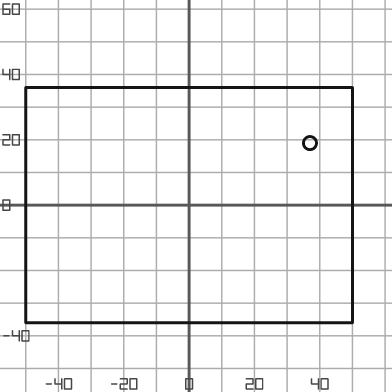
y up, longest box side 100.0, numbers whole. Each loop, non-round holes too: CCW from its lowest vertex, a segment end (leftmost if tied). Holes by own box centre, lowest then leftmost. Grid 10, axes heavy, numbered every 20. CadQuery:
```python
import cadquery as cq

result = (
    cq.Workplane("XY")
    .moveTo(-50.0, -36.0)
    .lineTo(50.0, -36.0)
    .lineTo(50.0, 36.0)
    .lineTo(-50.0, 36.0)
    .close()
    .moveTo(37.0, 19.0)
    .circle(2.0)
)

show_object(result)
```